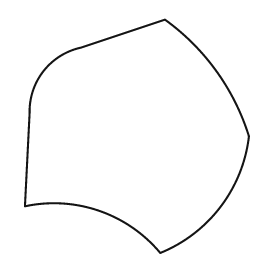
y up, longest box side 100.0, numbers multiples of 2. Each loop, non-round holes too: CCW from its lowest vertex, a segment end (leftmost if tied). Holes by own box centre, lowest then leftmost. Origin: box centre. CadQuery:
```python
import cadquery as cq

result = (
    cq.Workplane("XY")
    .moveTo(10.0, -50.0)
    .threePointArc((36.0, -30.0), (48.0, 0.0))
    .threePointArc((34.0, 28.0), (12.0, 50.0))
    .lineTo(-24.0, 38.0)
    .threePointArc((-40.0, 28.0), (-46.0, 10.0))
    .lineTo(-48.0, -30.0)
    .threePointArc((-16.0, -32.0), (10.0, -50.0))
    .close()
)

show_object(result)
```